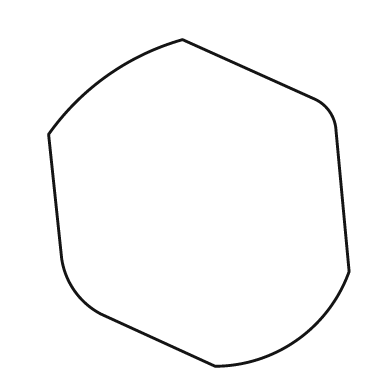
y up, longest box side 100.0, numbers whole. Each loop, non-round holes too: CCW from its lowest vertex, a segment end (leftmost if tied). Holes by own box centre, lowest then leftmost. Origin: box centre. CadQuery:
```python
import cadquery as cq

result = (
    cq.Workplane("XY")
    .moveTo(5.0, -50.0)
    .threePointArc((30.0, -42.0), (46.0, -21.0))
    .lineTo(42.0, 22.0)
    .threePointArc((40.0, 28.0), (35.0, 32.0))
    .lineTo(-5.0, 50.0)
    .threePointArc((-28.0, 39.0), (-46.0, 21.0))
    .lineTo(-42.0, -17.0)
    .threePointArc((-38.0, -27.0), (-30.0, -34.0))
    .close()
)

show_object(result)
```